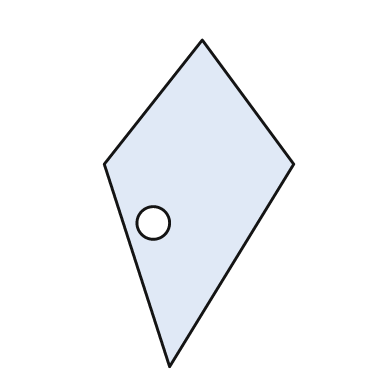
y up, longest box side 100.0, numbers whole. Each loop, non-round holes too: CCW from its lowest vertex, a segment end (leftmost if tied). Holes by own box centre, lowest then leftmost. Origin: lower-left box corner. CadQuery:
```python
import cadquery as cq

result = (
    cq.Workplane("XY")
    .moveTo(20.0, 0.0)
    .lineTo(58.0, 62.0)
    .lineTo(30.0, 100.0)
    .lineTo(0.0, 62.0)
    .close()
    .moveTo(15.0, 44.0)
    .circle(5.0)
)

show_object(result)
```